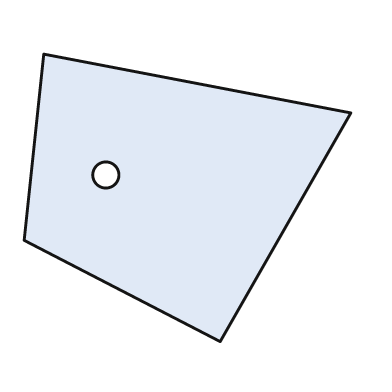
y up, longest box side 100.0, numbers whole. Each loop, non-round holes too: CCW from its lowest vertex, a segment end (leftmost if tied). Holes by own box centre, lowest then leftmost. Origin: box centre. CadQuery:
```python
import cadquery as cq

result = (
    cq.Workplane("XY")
    .moveTo(10.0, -44.0)
    .lineTo(50.0, 26.0)
    .lineTo(-44.0, 44.0)
    .lineTo(-50.0, -13.0)
    .close()
    .moveTo(-25.0, 7.0)
    .circle(4.0)
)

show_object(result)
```